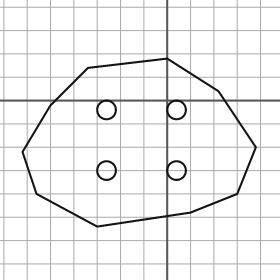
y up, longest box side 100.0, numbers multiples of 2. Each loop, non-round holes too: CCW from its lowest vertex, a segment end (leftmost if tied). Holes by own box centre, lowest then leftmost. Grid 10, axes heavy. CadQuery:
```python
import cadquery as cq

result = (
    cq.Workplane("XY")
    .moveTo(-30.0, -54.0)
    .lineTo(10.0, -48.0)
    .lineTo(30.0, -40.0)
    .lineTo(38.0, -20.0)
    .lineTo(22.0, 4.0)
    .lineTo(0.0, 18.0)
    .lineTo(-34.0, 14.0)
    .lineTo(-50.0, -2.0)
    .lineTo(-62.0, -22.0)
    .lineTo(-56.0, -40.0)
    .close()
    .moveTo(-26.0, -30.0)
    .circle(4.0)
    .moveTo(4.0, -30.0)
    .circle(4.0)
    .moveTo(-26.0, -4.0)
    .circle(4.0)
    .moveTo(4.0, -4.0)
    .circle(4.0)
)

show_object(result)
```